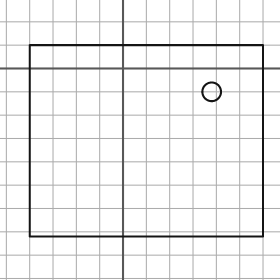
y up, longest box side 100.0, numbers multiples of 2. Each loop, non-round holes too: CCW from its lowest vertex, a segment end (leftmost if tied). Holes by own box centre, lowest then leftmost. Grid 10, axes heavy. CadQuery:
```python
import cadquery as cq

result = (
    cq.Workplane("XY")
    .moveTo(-40.0, -72.0)
    .lineTo(60.0, -72.0)
    .lineTo(60.0, 10.0)
    .lineTo(-40.0, 10.0)
    .close()
    .moveTo(38.0, -10.0)
    .circle(4.0)
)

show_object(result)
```